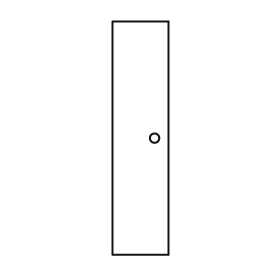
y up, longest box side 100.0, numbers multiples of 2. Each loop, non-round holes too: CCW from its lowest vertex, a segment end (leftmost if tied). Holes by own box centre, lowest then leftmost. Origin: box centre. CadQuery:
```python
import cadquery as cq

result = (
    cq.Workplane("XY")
    .moveTo(-12.0, -50.0)
    .lineTo(12.0, -50.0)
    .lineTo(12.0, 50.0)
    .lineTo(-12.0, 50.0)
    .close()
    .moveTo(6.0, 0.0)
    .circle(2.0)
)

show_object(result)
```